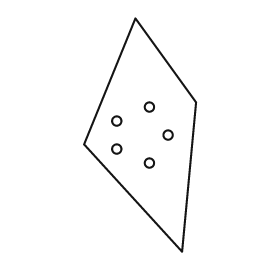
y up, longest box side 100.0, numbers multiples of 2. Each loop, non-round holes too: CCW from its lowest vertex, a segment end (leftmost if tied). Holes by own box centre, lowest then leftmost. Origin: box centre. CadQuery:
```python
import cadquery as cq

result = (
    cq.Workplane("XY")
    .moveTo(18.0, -50.0)
    .lineTo(24.0, 14.0)
    .lineTo(-2.0, 50.0)
    .lineTo(-24.0, -4.0)
    .close()
    .moveTo(4.0, -12.0)
    .circle(2.0)
    .moveTo(-10.0, -6.0)
    .circle(2.0)
    .moveTo(12.0, 0.0)
    .circle(2.0)
    .moveTo(-10.0, 6.0)
    .circle(2.0)
    .moveTo(4.0, 12.0)
    .circle(2.0)
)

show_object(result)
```